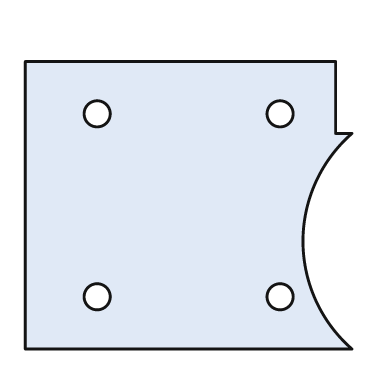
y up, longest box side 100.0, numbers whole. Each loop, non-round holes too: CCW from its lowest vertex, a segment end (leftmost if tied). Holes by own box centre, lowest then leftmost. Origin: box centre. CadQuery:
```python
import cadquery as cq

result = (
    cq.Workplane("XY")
    .moveTo(-50.0, -44.0)
    .lineTo(50.0, -44.0)
    .threePointArc((35.0, -11.0), (50.0, 22.0))
    .lineTo(45.0, 22.0)
    .lineTo(45.0, 44.0)
    .lineTo(-50.0, 44.0)
    .close()
    .moveTo(-28.0, -28.0)
    .circle(4.0)
    .moveTo(28.0, -28.0)
    .circle(4.0)
    .moveTo(-28.0, 28.0)
    .circle(4.0)
    .moveTo(28.0, 28.0)
    .circle(4.0)
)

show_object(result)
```